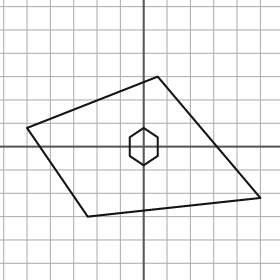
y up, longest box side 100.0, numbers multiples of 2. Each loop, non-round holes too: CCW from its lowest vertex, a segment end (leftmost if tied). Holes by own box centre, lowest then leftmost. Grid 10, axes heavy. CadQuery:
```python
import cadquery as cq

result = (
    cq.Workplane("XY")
    .moveTo(-24.0, -30.0)
    .lineTo(50.0, -22.0)
    .lineTo(6.0, 30.0)
    .lineTo(-50.0, 8.0)
    .close()
    .moveTo(0.0, -8.0)
    .lineTo(6.0, -4.0)
    .lineTo(6.0, 4.0)
    .lineTo(0.0, 8.0)
    .lineTo(-6.0, 4.0)
    .lineTo(-6.0, -4.0)
    .close()
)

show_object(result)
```